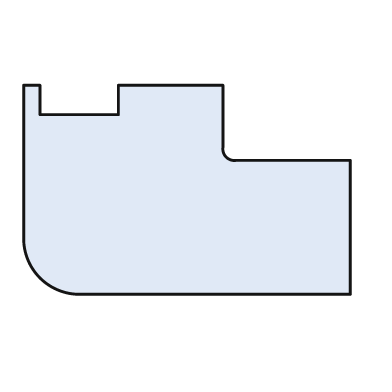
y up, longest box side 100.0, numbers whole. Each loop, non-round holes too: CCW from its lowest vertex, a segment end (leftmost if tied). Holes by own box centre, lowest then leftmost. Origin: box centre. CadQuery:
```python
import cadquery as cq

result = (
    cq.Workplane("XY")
    .moveTo(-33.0, -32.0)
    .lineTo(50.0, -32.0)
    .lineTo(50.0, 9.0)
    .lineTo(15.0, 9.0)
    .threePointArc((12.0, 10.0), (11.0, 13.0))
    .lineTo(11.0, 32.0)
    .lineTo(-21.0, 32.0)
    .lineTo(-21.0, 23.0)
    .lineTo(-45.0, 23.0)
    .lineTo(-45.0, 32.0)
    .lineTo(-50.0, 32.0)
    .lineTo(-50.0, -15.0)
    .threePointArc((-45.0, -27.0), (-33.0, -32.0))
    .close()
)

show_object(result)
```